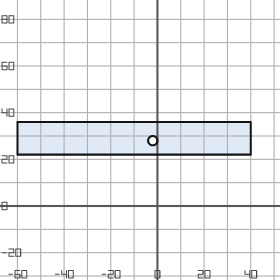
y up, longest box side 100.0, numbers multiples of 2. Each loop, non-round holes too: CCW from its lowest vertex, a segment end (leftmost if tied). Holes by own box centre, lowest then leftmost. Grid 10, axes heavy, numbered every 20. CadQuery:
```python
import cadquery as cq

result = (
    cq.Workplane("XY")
    .moveTo(-60.0, 22.0)
    .lineTo(40.0, 22.0)
    .lineTo(40.0, 36.0)
    .lineTo(-60.0, 36.0)
    .close()
    .moveTo(-2.0, 28.0)
    .circle(2.0)
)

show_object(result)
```